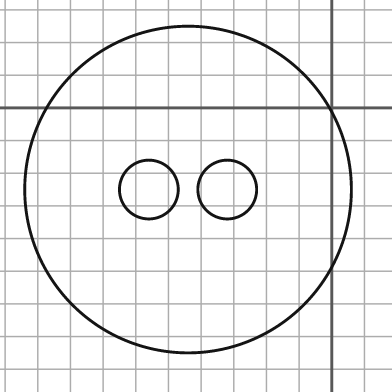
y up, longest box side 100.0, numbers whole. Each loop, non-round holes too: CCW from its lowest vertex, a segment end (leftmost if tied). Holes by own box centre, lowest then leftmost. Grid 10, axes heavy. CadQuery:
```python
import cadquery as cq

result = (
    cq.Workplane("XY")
    .moveTo(-44.0, -25.0)
    .circle(50.0)
    .moveTo(-56.0, -25.0)
    .circle(9.0)
    .moveTo(-32.0, -25.0)
    .circle(9.0)
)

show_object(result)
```